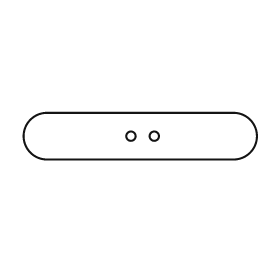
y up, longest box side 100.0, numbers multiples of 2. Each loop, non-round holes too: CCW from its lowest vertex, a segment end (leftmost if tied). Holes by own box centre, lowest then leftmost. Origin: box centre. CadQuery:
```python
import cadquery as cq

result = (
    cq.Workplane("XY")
    .moveTo(-40.0, -10.0)
    .lineTo(40.0, -10.0)
    .threePointArc((50.0, 0.0), (40.0, 10.0))
    .lineTo(-40.0, 10.0)
    .threePointArc((-50.0, 0.0), (-40.0, -10.0))
    .close()
    .moveTo(-4.0, 0.0)
    .circle(2.0)
    .moveTo(6.0, 0.0)
    .circle(2.0)
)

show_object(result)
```